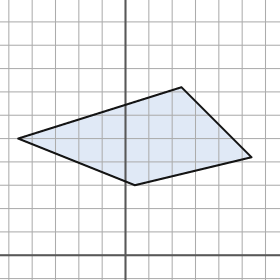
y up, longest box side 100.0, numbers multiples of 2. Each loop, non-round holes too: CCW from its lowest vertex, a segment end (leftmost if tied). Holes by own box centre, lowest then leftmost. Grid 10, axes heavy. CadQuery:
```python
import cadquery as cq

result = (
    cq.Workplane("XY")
    .moveTo(4.0, 30.0)
    .lineTo(54.0, 42.0)
    .lineTo(24.0, 72.0)
    .lineTo(-46.0, 50.0)
    .close()
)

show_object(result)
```